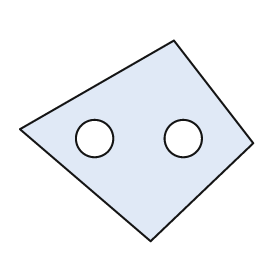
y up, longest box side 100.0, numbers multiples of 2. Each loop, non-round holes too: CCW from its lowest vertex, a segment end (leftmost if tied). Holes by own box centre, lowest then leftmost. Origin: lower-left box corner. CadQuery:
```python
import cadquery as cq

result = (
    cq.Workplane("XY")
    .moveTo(56.0, 0.0)
    .lineTo(100.0, 42.0)
    .lineTo(66.0, 86.0)
    .lineTo(0.0, 48.0)
    .close()
    .moveTo(32.0, 44.0)
    .circle(8.0)
    .moveTo(70.0, 44.0)
    .circle(8.0)
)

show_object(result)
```